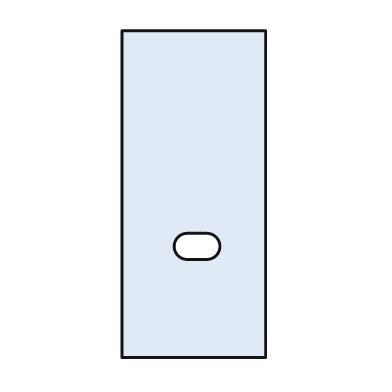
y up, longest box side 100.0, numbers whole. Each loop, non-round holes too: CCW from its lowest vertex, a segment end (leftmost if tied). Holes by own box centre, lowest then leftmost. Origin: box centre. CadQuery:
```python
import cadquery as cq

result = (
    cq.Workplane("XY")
    .moveTo(-22.0, -50.0)
    .lineTo(22.0, -50.0)
    .lineTo(22.0, 50.0)
    .lineTo(-22.0, 50.0)
    .close()
    .moveTo(-2.0, -20.0)
    .lineTo(4.0, -20.0)
    .threePointArc((8.0, -16.0), (4.0, -12.0))
    .lineTo(-2.0, -12.0)
    .threePointArc((-6.0, -16.0), (-2.0, -20.0))
    .close()
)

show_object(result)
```